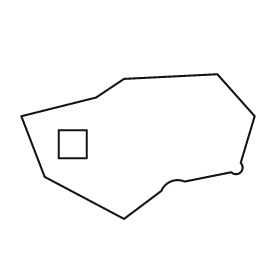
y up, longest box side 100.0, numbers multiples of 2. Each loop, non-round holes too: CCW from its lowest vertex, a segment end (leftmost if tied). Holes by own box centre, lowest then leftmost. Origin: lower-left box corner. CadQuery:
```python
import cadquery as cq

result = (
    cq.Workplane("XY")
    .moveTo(44.0, 0.0)
    .lineTo(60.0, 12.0)
    .threePointArc((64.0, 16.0), (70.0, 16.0))
    .lineTo(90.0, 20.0)
    .threePointArc((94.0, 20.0), (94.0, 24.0))
    .lineTo(100.0, 44.0)
    .lineTo(84.0, 62.0)
    .lineTo(44.0, 60.0)
    .lineTo(32.0, 52.0)
    .lineTo(0.0, 44.0)
    .lineTo(10.0, 18.0)
    .close()
    .moveTo(16.0, 26.0)
    .lineTo(28.0, 26.0)
    .lineTo(28.0, 38.0)
    .lineTo(16.0, 38.0)
    .close()
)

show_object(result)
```